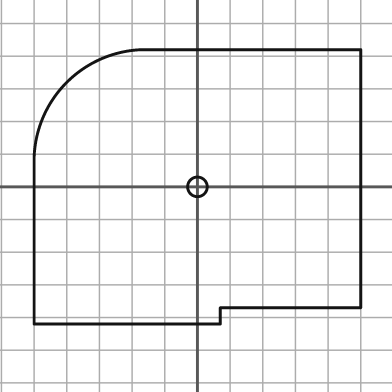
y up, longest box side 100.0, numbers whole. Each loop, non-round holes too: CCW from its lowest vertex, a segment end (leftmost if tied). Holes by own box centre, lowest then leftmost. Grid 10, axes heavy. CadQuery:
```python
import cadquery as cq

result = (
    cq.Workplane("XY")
    .moveTo(-50.0, -42.0)
    .lineTo(7.0, -42.0)
    .lineTo(7.0, -37.0)
    .lineTo(50.0, -37.0)
    .lineTo(50.0, 42.0)
    .lineTo(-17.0, 42.0)
    .threePointArc((-40.0, 32.0), (-50.0, 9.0))
    .close()
    .moveTo(0.0, 0.0)
    .circle(3.0)
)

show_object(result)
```